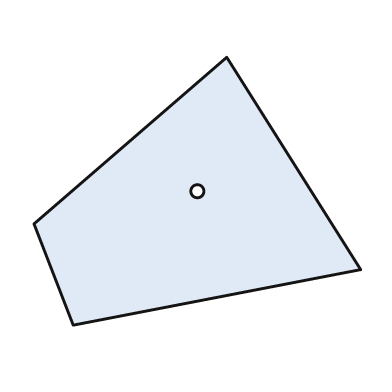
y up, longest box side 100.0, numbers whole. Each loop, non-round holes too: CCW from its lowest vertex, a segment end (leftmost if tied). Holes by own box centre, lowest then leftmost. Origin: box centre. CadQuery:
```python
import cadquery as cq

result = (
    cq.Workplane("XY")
    .moveTo(-38.0, -41.0)
    .lineTo(50.0, -24.0)
    .lineTo(9.0, 41.0)
    .lineTo(-50.0, -10.0)
    .close()
    .moveTo(0.0, 0.0)
    .circle(2.0)
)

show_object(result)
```